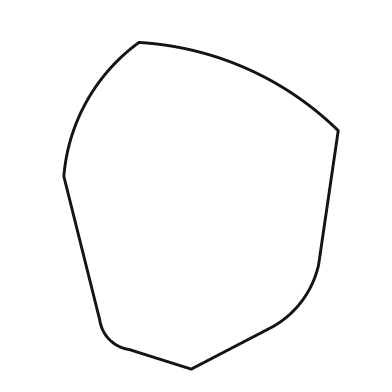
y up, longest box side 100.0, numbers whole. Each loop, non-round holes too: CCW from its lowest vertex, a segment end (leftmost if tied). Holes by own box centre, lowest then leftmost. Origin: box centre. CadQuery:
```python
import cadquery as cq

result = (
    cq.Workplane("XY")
    .moveTo(-3.0, -50.0)
    .lineTo(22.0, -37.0)
    .threePointArc((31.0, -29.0), (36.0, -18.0))
    .lineTo(42.0, 23.0)
    .threePointArc((14.0, 42.0), (-19.0, 50.0))
    .threePointArc((-35.0, 32.0), (-42.0, 9.0))
    .lineTo(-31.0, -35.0)
    .threePointArc((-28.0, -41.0), (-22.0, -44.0))
    .close()
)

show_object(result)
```